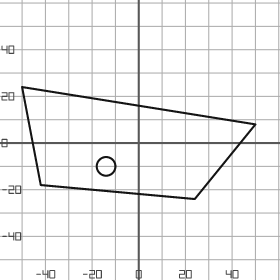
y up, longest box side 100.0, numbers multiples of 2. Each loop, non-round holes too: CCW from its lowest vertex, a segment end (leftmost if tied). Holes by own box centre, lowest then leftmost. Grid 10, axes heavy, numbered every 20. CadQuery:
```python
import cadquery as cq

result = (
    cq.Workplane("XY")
    .moveTo(24.0, -24.0)
    .lineTo(50.0, 8.0)
    .lineTo(-50.0, 24.0)
    .lineTo(-42.0, -18.0)
    .close()
    .moveTo(-14.0, -10.0)
    .circle(4.0)
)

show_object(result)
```